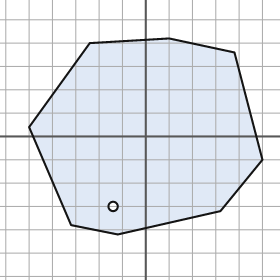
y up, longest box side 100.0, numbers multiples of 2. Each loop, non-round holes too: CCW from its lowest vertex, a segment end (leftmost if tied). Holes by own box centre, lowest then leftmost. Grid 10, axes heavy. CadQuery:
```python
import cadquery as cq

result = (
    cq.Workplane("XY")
    .moveTo(-12.0, -42.0)
    .lineTo(32.0, -32.0)
    .lineTo(50.0, -10.0)
    .lineTo(38.0, 36.0)
    .lineTo(10.0, 42.0)
    .lineTo(-24.0, 40.0)
    .lineTo(-50.0, 4.0)
    .lineTo(-32.0, -38.0)
    .close()
    .moveTo(-14.0, -30.0)
    .circle(2.0)
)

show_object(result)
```